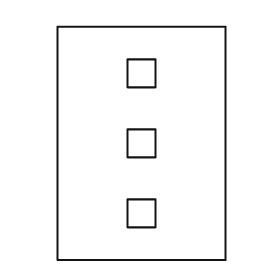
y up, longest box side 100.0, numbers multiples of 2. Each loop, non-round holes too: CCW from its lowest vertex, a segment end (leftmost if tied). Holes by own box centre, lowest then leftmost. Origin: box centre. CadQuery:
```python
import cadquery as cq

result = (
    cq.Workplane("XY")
    .moveTo(-36.0, -50.0)
    .lineTo(36.0, -50.0)
    .lineTo(36.0, 50.0)
    .lineTo(-36.0, 50.0)
    .close()
    .moveTo(-6.0, -36.0)
    .lineTo(6.0, -36.0)
    .lineTo(6.0, -24.0)
    .lineTo(-6.0, -24.0)
    .close()
    .moveTo(-6.0, -6.0)
    .lineTo(6.0, -6.0)
    .lineTo(6.0, 6.0)
    .lineTo(-6.0, 6.0)
    .close()
    .moveTo(-6.0, 24.0)
    .lineTo(6.0, 24.0)
    .lineTo(6.0, 36.0)
    .lineTo(-6.0, 36.0)
    .close()
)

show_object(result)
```